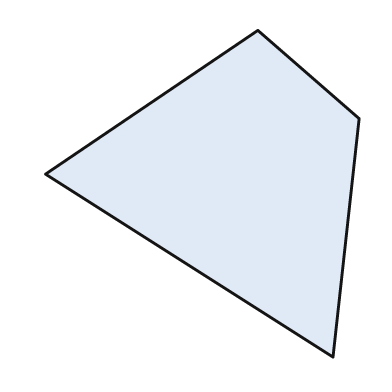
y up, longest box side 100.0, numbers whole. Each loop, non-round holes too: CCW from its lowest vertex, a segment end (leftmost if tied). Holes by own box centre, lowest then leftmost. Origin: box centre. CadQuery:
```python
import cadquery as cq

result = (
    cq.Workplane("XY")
    .moveTo(40.0, -50.0)
    .lineTo(48.0, 23.0)
    .lineTo(17.0, 50.0)
    .lineTo(-48.0, 6.0)
    .close()
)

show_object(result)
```